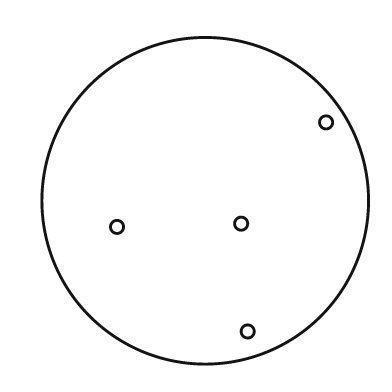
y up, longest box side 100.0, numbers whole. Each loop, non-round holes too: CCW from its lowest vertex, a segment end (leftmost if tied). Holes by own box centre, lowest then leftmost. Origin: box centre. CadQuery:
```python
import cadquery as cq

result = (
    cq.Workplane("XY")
    .moveTo(0.0, 0.0)
    .circle(50.0)
    .moveTo(13.0, -40.0)
    .circle(2.0)
    .moveTo(-27.0, -8.0)
    .circle(2.0)
    .moveTo(11.0, -7.0)
    .circle(2.0)
    .moveTo(37.0, 24.0)
    .circle(2.0)
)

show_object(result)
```